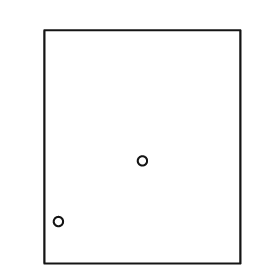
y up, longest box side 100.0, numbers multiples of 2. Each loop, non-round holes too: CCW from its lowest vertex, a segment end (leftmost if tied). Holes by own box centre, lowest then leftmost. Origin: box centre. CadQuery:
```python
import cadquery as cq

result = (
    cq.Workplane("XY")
    .moveTo(-42.0, -50.0)
    .lineTo(42.0, -50.0)
    .lineTo(42.0, 50.0)
    .lineTo(-42.0, 50.0)
    .close()
    .moveTo(-36.0, -32.0)
    .circle(2.0)
    .moveTo(0.0, -6.0)
    .circle(2.0)
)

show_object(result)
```